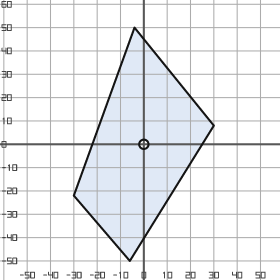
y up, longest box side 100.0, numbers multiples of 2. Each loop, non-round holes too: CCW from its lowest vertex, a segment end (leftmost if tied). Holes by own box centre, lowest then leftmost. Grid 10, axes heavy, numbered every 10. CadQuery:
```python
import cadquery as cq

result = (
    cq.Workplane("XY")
    .moveTo(-6.0, -50.0)
    .lineTo(30.0, 8.0)
    .lineTo(-4.0, 50.0)
    .lineTo(-30.0, -22.0)
    .close()
    .moveTo(0.0, 0.0)
    .circle(2.0)
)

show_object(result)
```